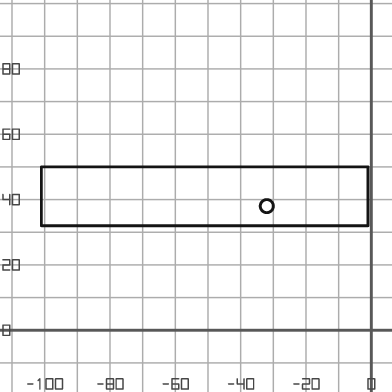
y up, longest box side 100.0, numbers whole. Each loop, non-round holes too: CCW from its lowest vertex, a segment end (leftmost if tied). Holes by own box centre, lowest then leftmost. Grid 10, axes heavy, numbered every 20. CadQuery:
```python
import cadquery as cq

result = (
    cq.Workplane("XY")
    .moveTo(-101.0, 32.0)
    .lineTo(-1.0, 32.0)
    .lineTo(-1.0, 50.0)
    .lineTo(-101.0, 50.0)
    .close()
    .moveTo(-32.0, 38.0)
    .circle(2.0)
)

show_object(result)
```